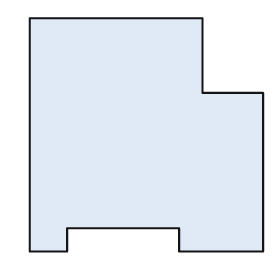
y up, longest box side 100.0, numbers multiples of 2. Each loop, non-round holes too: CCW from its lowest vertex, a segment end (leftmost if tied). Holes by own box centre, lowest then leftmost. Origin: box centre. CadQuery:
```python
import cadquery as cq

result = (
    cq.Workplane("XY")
    .moveTo(-50.0, -50.0)
    .lineTo(-34.0, -50.0)
    .lineTo(-34.0, -40.0)
    .lineTo(14.0, -40.0)
    .lineTo(14.0, -50.0)
    .lineTo(50.0, -50.0)
    .lineTo(50.0, 18.0)
    .lineTo(24.0, 18.0)
    .lineTo(24.0, 50.0)
    .lineTo(-50.0, 50.0)
    .close()
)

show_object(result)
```